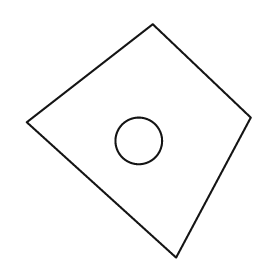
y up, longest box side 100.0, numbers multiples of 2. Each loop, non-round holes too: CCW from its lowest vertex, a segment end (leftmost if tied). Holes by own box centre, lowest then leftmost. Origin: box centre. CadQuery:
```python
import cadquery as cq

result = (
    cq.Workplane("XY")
    .moveTo(16.0, -50.0)
    .lineTo(48.0, 10.0)
    .lineTo(6.0, 50.0)
    .lineTo(-48.0, 8.0)
    .close()
    .moveTo(0.0, 0.0)
    .circle(10.0)
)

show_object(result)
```